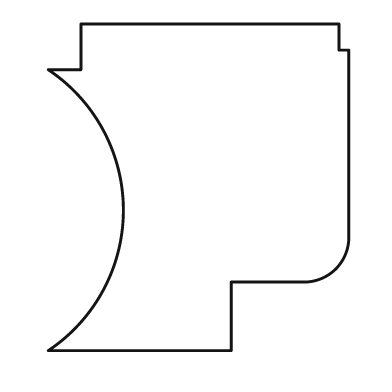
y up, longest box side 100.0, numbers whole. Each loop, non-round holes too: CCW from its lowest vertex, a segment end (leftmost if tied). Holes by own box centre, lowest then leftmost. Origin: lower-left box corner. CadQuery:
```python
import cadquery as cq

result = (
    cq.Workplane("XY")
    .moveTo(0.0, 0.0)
    .lineTo(56.0, 0.0)
    .lineTo(56.0, 21.0)
    .lineTo(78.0, 21.0)
    .threePointArc((88.0, 25.0), (92.0, 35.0))
    .lineTo(92.0, 92.0)
    .lineTo(89.0, 92.0)
    .lineTo(89.0, 100.0)
    .lineTo(10.0, 100.0)
    .lineTo(10.0, 86.0)
    .lineTo(0.0, 86.0)
    .threePointArc((23.0, 43.0), (0.0, 0.0))
    .close()
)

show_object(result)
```